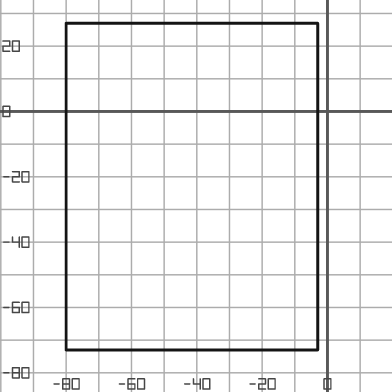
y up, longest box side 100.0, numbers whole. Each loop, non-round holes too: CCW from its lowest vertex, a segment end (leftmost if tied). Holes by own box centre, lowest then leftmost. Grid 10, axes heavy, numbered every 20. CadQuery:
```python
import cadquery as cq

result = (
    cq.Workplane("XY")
    .moveTo(-80.0, -73.0)
    .lineTo(-3.0, -73.0)
    .lineTo(-3.0, 27.0)
    .lineTo(-80.0, 27.0)
    .close()
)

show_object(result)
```